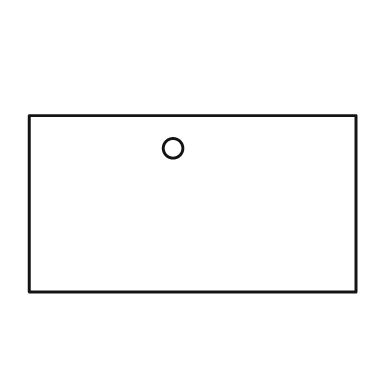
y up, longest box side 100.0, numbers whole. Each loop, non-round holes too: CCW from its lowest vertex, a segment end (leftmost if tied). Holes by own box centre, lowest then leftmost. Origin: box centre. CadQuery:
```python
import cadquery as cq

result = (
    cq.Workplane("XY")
    .moveTo(-50.0, -27.0)
    .lineTo(50.0, -27.0)
    .lineTo(50.0, 27.0)
    .lineTo(-50.0, 27.0)
    .close()
    .moveTo(-6.0, 17.0)
    .circle(3.0)
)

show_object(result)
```